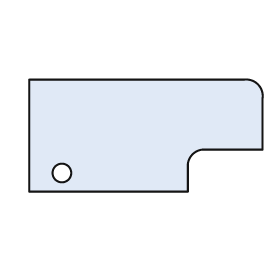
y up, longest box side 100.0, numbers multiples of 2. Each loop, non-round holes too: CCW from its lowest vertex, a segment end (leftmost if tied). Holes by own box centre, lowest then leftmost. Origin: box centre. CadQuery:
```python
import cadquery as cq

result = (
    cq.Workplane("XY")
    .moveTo(-50.0, -24.0)
    .lineTo(18.0, -24.0)
    .lineTo(18.0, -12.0)
    .threePointArc((20.0, -8.0), (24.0, -6.0))
    .lineTo(50.0, -6.0)
    .lineTo(50.0, 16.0)
    .threePointArc((48.0, 22.0), (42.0, 24.0))
    .lineTo(-50.0, 24.0)
    .close()
    .moveTo(-36.0, -16.0)
    .circle(4.0)
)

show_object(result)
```